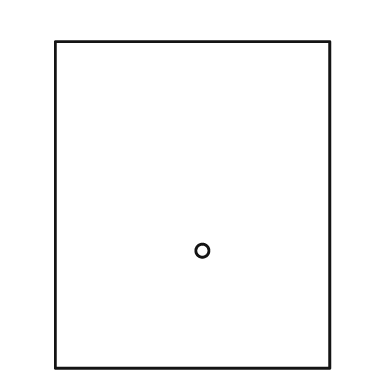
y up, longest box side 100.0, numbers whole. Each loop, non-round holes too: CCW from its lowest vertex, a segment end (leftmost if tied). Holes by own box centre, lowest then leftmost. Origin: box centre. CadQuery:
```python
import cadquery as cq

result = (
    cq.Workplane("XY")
    .moveTo(-42.0, -50.0)
    .lineTo(42.0, -50.0)
    .lineTo(42.0, 50.0)
    .lineTo(-42.0, 50.0)
    .close()
    .moveTo(3.0, -14.0)
    .circle(2.0)
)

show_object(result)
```